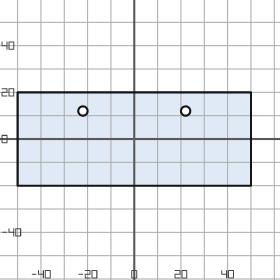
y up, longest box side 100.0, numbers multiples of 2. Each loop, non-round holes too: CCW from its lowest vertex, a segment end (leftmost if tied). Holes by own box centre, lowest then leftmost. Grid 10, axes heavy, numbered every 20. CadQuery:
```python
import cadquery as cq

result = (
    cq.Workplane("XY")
    .moveTo(-50.0, -20.0)
    .lineTo(50.0, -20.0)
    .lineTo(50.0, 20.0)
    .lineTo(-50.0, 20.0)
    .close()
    .moveTo(-22.0, 12.0)
    .circle(2.0)
    .moveTo(22.0, 12.0)
    .circle(2.0)
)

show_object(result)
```